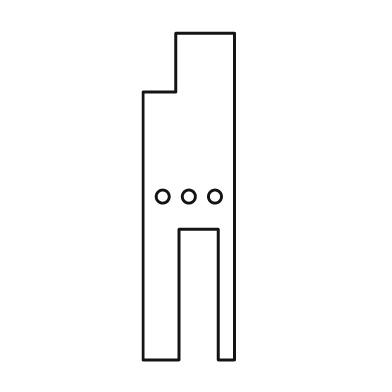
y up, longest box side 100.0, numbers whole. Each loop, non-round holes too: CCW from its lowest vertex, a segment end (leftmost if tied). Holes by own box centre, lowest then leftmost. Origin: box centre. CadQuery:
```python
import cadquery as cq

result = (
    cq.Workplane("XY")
    .moveTo(-14.0, -50.0)
    .lineTo(-3.0, -50.0)
    .lineTo(-3.0, -10.0)
    .lineTo(9.0, -10.0)
    .lineTo(9.0, -50.0)
    .lineTo(14.0, -50.0)
    .lineTo(14.0, 50.0)
    .lineTo(-4.0, 50.0)
    .lineTo(-4.0, 32.0)
    .lineTo(-14.0, 32.0)
    .close()
    .moveTo(-8.0, 0.0)
    .circle(2.0)
    .moveTo(0.0, 0.0)
    .circle(2.0)
    .moveTo(8.0, 0.0)
    .circle(2.0)
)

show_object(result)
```